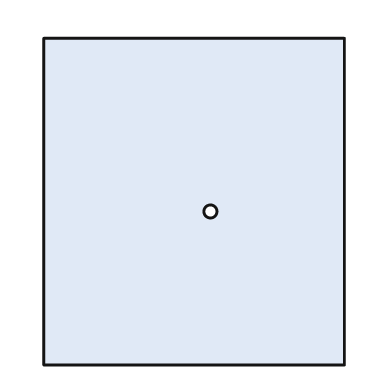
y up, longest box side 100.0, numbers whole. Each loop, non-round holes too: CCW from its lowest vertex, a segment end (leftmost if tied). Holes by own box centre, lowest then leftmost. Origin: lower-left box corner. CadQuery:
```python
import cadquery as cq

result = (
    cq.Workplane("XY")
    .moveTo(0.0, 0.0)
    .lineTo(92.0, 0.0)
    .lineTo(92.0, 100.0)
    .lineTo(0.0, 100.0)
    .close()
    .moveTo(51.0, 47.0)
    .circle(2.0)
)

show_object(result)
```